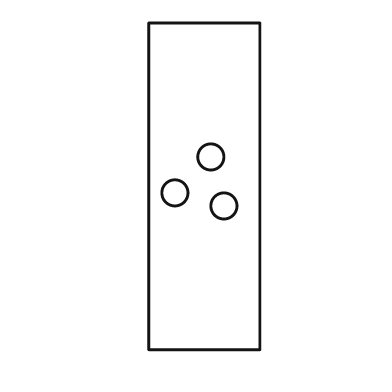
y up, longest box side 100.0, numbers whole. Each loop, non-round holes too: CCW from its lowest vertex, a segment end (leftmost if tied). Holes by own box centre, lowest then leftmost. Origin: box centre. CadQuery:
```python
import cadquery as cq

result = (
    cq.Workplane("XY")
    .moveTo(-17.0, -50.0)
    .lineTo(17.0, -50.0)
    .lineTo(17.0, 50.0)
    .lineTo(-17.0, 50.0)
    .close()
    .moveTo(6.0, -6.0)
    .circle(4.0)
    .moveTo(-9.0, -2.0)
    .circle(4.0)
    .moveTo(2.0, 9.0)
    .circle(4.0)
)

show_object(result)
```